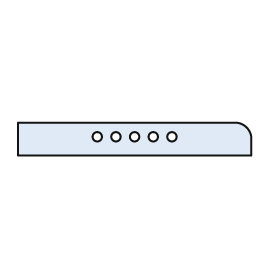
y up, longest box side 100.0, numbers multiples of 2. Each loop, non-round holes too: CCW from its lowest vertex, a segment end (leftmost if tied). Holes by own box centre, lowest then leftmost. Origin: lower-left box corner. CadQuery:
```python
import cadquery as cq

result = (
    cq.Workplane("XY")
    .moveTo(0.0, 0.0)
    .lineTo(100.0, 0.0)
    .lineTo(100.0, 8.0)
    .threePointArc((98.0, 12.0), (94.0, 14.0))
    .lineTo(0.0, 14.0)
    .close()
    .moveTo(34.0, 8.0)
    .circle(2.0)
    .moveTo(42.0, 8.0)
    .circle(2.0)
    .moveTo(50.0, 8.0)
    .circle(2.0)
    .moveTo(58.0, 8.0)
    .circle(2.0)
    .moveTo(66.0, 8.0)
    .circle(2.0)
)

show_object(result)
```